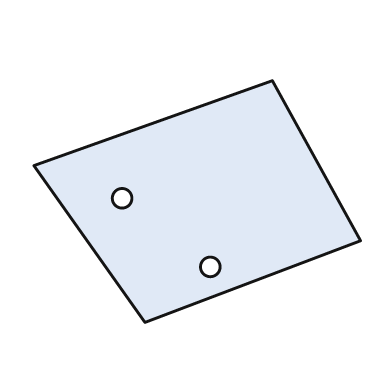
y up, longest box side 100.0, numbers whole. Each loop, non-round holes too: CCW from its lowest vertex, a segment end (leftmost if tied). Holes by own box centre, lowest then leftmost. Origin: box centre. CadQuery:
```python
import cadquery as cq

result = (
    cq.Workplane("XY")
    .moveTo(-16.0, -37.0)
    .lineTo(50.0, -12.0)
    .lineTo(23.0, 37.0)
    .lineTo(-50.0, 11.0)
    .close()
    .moveTo(4.0, -20.0)
    .circle(3.0)
    .moveTo(-23.0, 1.0)
    .circle(3.0)
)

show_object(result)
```